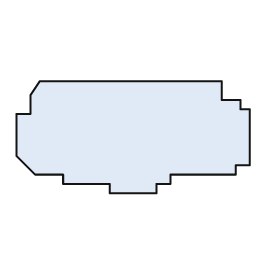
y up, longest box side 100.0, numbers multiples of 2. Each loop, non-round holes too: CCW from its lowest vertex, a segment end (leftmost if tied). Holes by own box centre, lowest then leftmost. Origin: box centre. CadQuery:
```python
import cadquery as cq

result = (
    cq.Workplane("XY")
    .moveTo(-10.0, -24.0)
    .lineTo(10.0, -24.0)
    .lineTo(10.0, -20.0)
    .lineTo(16.0, -20.0)
    .lineTo(16.0, -16.0)
    .lineTo(44.0, -16.0)
    .lineTo(44.0, -12.0)
    .lineTo(50.0, -12.0)
    .lineTo(50.0, 12.0)
    .lineTo(46.0, 12.0)
    .lineTo(46.0, 16.0)
    .lineTo(38.0, 16.0)
    .lineTo(38.0, 24.0)
    .lineTo(-40.0, 24.0)
    .lineTo(-44.0, 18.0)
    .lineTo(-44.0, 10.0)
    .lineTo(-50.0, 10.0)
    .lineTo(-50.0, -8.0)
    .lineTo(-42.0, -16.0)
    .lineTo(-30.0, -16.0)
    .lineTo(-30.0, -20.0)
    .lineTo(-10.0, -20.0)
    .close()
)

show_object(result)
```